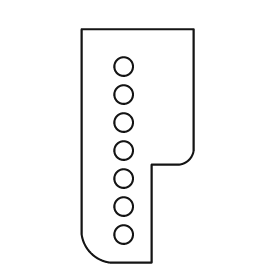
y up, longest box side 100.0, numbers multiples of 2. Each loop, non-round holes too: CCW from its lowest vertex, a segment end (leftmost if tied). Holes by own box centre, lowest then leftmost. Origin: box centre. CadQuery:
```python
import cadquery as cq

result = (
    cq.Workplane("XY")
    .moveTo(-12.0, -50.0)
    .lineTo(6.0, -50.0)
    .lineTo(6.0, -8.0)
    .lineTo(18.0, -8.0)
    .threePointArc((22.0, -6.0), (24.0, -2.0))
    .lineTo(24.0, 50.0)
    .lineTo(-24.0, 50.0)
    .lineTo(-24.0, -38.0)
    .threePointArc((-20.0, -46.0), (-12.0, -50.0))
    .close()
    .moveTo(-6.0, -38.0)
    .circle(4.0)
    .moveTo(-6.0, -26.0)
    .circle(4.0)
    .moveTo(-6.0, -14.0)
    .circle(4.0)
    .moveTo(-6.0, -2.0)
    .circle(4.0)
    .moveTo(-6.0, 10.0)
    .circle(4.0)
    .moveTo(-6.0, 22.0)
    .circle(4.0)
    .moveTo(-6.0, 34.0)
    .circle(4.0)
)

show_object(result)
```